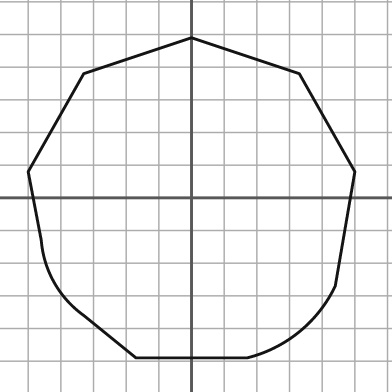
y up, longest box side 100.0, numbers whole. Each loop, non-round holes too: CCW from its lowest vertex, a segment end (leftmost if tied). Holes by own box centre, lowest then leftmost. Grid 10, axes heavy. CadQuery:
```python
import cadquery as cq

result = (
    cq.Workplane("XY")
    .moveTo(-17.0, -49.0)
    .lineTo(17.0, -49.0)
    .threePointArc((33.0, -41.0), (44.0, -27.0))
    .lineTo(50.0, 8.0)
    .lineTo(33.0, 38.0)
    .lineTo(0.0, 49.0)
    .lineTo(-33.0, 38.0)
    .lineTo(-50.0, 8.0)
    .lineTo(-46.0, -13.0)
    .threePointArc((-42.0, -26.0), (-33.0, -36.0))
    .close()
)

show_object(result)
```